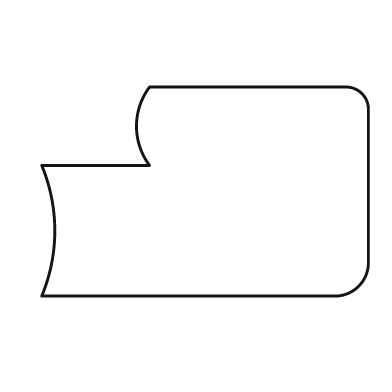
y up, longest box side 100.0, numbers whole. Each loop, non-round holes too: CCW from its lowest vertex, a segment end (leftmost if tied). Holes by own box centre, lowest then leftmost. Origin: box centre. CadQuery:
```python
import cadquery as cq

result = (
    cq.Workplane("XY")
    .moveTo(-50.0, -32.0)
    .lineTo(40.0, -32.0)
    .threePointArc((47.0, -29.0), (50.0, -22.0))
    .lineTo(50.0, 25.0)
    .threePointArc((48.0, 30.0), (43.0, 32.0))
    .lineTo(-17.0, 32.0)
    .threePointArc((-21.0, 20.0), (-17.0, 8.0))
    .lineTo(-50.0, 8.0)
    .threePointArc((-46.0, -12.0), (-50.0, -32.0))
    .close()
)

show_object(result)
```